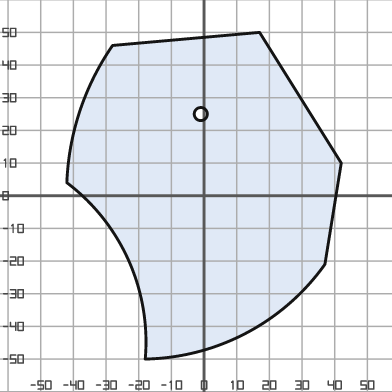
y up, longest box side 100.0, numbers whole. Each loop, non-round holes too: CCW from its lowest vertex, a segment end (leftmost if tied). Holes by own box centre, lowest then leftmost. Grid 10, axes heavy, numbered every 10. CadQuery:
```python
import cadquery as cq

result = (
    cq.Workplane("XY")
    .moveTo(-18.0, -50.0)
    .threePointArc((13.0, -42.0), (37.0, -21.0))
    .lineTo(42.0, 10.0)
    .lineTo(17.0, 50.0)
    .lineTo(-28.0, 46.0)
    .threePointArc((-38.0, 26.0), (-42.0, 4.0))
    .threePointArc((-23.0, -20.0), (-18.0, -50.0))
    .close()
    .moveTo(-1.0, 25.0)
    .circle(2.0)
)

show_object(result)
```